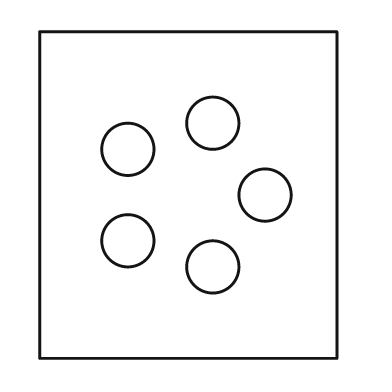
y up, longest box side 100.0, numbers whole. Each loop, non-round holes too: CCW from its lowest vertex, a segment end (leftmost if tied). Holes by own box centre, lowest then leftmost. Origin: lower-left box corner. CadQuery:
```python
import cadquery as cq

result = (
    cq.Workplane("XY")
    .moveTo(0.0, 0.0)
    .lineTo(91.0, 0.0)
    .lineTo(91.0, 100.0)
    .lineTo(0.0, 100.0)
    .close()
    .moveTo(53.0, 28.0)
    .circle(8.0)
    .moveTo(27.0, 36.0)
    .circle(8.0)
    .moveTo(69.0, 50.0)
    .circle(8.0)
    .moveTo(27.0, 64.0)
    .circle(8.0)
    .moveTo(53.0, 72.0)
    .circle(8.0)
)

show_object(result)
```